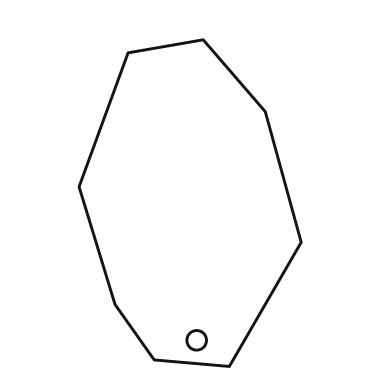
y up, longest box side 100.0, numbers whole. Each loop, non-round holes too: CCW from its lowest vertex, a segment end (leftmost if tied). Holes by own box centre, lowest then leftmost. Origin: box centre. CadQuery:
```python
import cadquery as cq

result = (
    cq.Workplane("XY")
    .moveTo(12.0, -50.0)
    .lineTo(34.0, -12.0)
    .lineTo(23.0, 28.0)
    .lineTo(4.0, 50.0)
    .lineTo(-19.0, 46.0)
    .lineTo(-34.0, 5.0)
    .lineTo(-23.0, -31.0)
    .lineTo(-11.0, -48.0)
    .close()
    .moveTo(2.0, -42.0)
    .circle(3.0)
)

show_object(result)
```